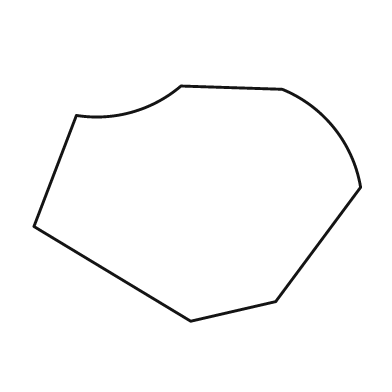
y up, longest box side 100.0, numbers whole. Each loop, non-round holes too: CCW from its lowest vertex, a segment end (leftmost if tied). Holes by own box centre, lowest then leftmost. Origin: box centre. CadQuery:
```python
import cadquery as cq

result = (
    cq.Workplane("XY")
    .moveTo(-2.0, -36.0)
    .lineTo(24.0, -30.0)
    .lineTo(50.0, 5.0)
    .threePointArc((42.0, 23.0), (26.0, 35.0))
    .lineTo(-5.0, 36.0)
    .threePointArc((-20.0, 28.0), (-37.0, 27.0))
    .lineTo(-50.0, -7.0)
    .close()
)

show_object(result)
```